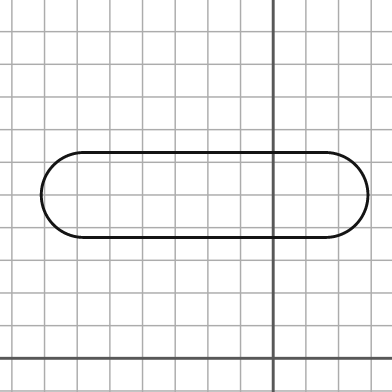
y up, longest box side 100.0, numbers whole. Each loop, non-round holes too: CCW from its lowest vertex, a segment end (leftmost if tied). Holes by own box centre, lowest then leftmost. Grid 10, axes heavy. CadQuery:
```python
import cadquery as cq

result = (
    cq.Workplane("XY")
    .moveTo(-58.0, 37.0)
    .lineTo(16.0, 37.0)
    .threePointArc((29.0, 50.0), (16.0, 63.0))
    .lineTo(-58.0, 63.0)
    .threePointArc((-71.0, 50.0), (-58.0, 37.0))
    .close()
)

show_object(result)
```